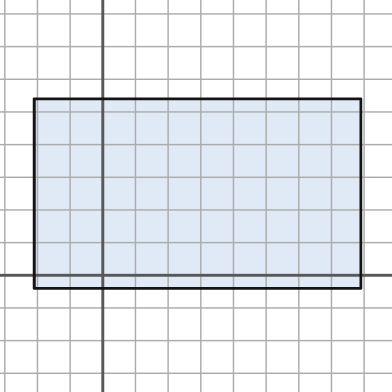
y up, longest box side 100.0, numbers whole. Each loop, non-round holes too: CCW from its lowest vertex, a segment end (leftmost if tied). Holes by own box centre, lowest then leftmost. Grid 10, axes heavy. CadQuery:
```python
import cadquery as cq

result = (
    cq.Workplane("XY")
    .moveTo(-21.0, -4.0)
    .lineTo(79.0, -4.0)
    .lineTo(79.0, 54.0)
    .lineTo(-21.0, 54.0)
    .close()
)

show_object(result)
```